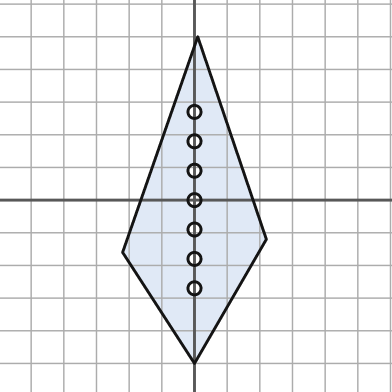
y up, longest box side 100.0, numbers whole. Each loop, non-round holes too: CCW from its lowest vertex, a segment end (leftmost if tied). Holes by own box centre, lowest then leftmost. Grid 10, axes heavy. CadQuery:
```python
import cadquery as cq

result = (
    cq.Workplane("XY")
    .moveTo(0.0, -50.0)
    .lineTo(22.0, -12.0)
    .lineTo(1.0, 50.0)
    .lineTo(-22.0, -16.0)
    .close()
    .moveTo(0.0, -27.0)
    .circle(2.0)
    .moveTo(0.0, -18.0)
    .circle(2.0)
    .moveTo(0.0, -9.0)
    .circle(2.0)
    .moveTo(0.0, 0.0)
    .circle(2.0)
    .moveTo(0.0, 9.0)
    .circle(2.0)
    .moveTo(0.0, 18.0)
    .circle(2.0)
    .moveTo(0.0, 27.0)
    .circle(2.0)
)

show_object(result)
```